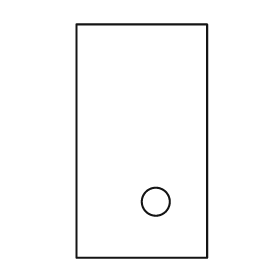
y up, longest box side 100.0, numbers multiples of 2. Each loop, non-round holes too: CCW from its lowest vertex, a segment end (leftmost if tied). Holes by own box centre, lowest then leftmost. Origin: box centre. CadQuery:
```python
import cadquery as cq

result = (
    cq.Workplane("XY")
    .moveTo(-28.0, -50.0)
    .lineTo(28.0, -50.0)
    .lineTo(28.0, 50.0)
    .lineTo(-28.0, 50.0)
    .close()
    .moveTo(6.0, -26.0)
    .circle(6.0)
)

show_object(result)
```